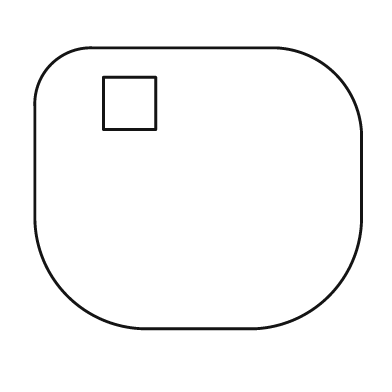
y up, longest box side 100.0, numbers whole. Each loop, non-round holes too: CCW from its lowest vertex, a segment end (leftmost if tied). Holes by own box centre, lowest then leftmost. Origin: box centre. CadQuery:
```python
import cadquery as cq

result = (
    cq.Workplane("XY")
    .moveTo(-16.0, -43.0)
    .lineTo(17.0, -43.0)
    .threePointArc((40.0, -33.0), (50.0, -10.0))
    .lineTo(50.0, 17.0)
    .threePointArc((42.0, 35.0), (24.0, 43.0))
    .lineTo(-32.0, 43.0)
    .threePointArc((-45.0, 38.0), (-50.0, 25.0))
    .lineTo(-50.0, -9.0)
    .threePointArc((-40.0, -33.0), (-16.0, -43.0))
    .close()
    .moveTo(-29.0, 18.0)
    .lineTo(-13.0, 18.0)
    .lineTo(-13.0, 34.0)
    .lineTo(-29.0, 34.0)
    .close()
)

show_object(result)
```